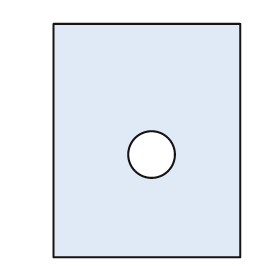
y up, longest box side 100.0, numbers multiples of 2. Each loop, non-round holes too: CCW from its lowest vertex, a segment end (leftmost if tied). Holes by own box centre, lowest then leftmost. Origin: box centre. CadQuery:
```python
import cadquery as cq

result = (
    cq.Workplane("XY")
    .moveTo(-40.0, -50.0)
    .lineTo(40.0, -50.0)
    .lineTo(40.0, 50.0)
    .lineTo(-40.0, 50.0)
    .close()
    .moveTo(2.0, -6.0)
    .circle(10.0)
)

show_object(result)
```